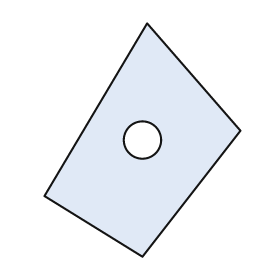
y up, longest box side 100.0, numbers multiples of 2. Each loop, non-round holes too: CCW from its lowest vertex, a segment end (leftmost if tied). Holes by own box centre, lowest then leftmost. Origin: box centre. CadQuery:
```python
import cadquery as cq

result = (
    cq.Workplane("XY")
    .moveTo(0.0, -50.0)
    .lineTo(42.0, 4.0)
    .lineTo(2.0, 50.0)
    .lineTo(-42.0, -24.0)
    .close()
    .moveTo(0.0, 0.0)
    .circle(8.0)
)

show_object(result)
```